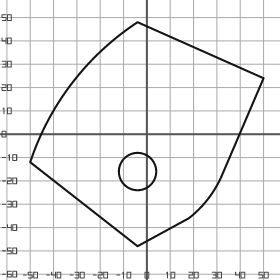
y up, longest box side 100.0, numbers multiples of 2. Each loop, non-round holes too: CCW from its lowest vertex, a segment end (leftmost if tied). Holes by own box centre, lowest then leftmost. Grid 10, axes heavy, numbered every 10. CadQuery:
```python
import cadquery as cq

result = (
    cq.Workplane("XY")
    .moveTo(-4.0, -48.0)
    .lineTo(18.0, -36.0)
    .threePointArc((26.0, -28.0), (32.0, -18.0))
    .lineTo(50.0, 24.0)
    .lineTo(-4.0, 48.0)
    .threePointArc((-32.0, 22.0), (-50.0, -12.0))
    .close()
    .moveTo(-4.0, -16.0)
    .circle(8.0)
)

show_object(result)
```